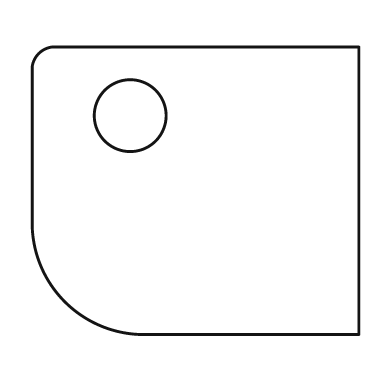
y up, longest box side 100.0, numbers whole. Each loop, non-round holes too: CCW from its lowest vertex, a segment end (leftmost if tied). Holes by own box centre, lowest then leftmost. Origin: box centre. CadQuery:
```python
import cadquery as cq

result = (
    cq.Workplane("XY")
    .moveTo(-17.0, -44.0)
    .lineTo(50.0, -44.0)
    .lineTo(50.0, 44.0)
    .lineTo(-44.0, 44.0)
    .threePointArc((-48.0, 42.0), (-50.0, 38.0))
    .lineTo(-50.0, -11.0)
    .threePointArc((-40.0, -34.0), (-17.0, -44.0))
    .close()
    .moveTo(-20.0, 23.0)
    .circle(11.0)
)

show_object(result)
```